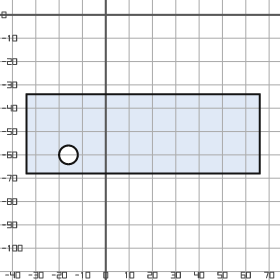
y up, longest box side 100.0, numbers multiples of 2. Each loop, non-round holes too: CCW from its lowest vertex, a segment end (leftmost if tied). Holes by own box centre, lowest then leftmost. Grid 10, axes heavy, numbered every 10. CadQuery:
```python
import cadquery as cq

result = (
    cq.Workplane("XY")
    .moveTo(-34.0, -68.0)
    .lineTo(66.0, -68.0)
    .lineTo(66.0, -34.0)
    .lineTo(-34.0, -34.0)
    .close()
    .moveTo(-16.0, -60.0)
    .circle(4.0)
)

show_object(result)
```